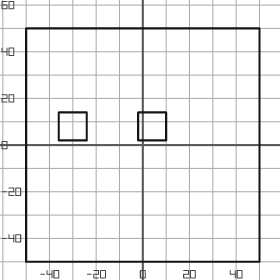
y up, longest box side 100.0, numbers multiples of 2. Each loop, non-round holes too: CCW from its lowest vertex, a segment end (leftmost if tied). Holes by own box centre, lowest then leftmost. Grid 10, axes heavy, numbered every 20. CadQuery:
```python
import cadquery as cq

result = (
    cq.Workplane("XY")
    .moveTo(-50.0, -50.0)
    .lineTo(50.0, -50.0)
    .lineTo(50.0, 50.0)
    .lineTo(-50.0, 50.0)
    .close()
    .moveTo(-36.0, 2.0)
    .lineTo(-24.0, 2.0)
    .lineTo(-24.0, 14.0)
    .lineTo(-36.0, 14.0)
    .close()
    .moveTo(-2.0, 2.0)
    .lineTo(10.0, 2.0)
    .lineTo(10.0, 14.0)
    .lineTo(-2.0, 14.0)
    .close()
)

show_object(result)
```